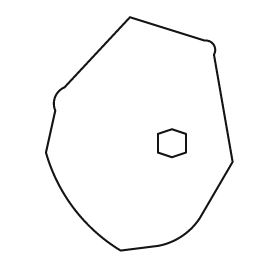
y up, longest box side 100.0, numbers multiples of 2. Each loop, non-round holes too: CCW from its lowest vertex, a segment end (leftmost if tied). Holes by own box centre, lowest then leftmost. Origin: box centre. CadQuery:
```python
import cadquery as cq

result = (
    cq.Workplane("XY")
    .moveTo(-8.0, -50.0)
    .lineTo(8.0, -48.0)
    .threePointArc((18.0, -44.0), (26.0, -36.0))
    .lineTo(40.0, -12.0)
    .lineTo(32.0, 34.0)
    .threePointArc((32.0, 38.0), (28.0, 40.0))
    .lineTo(-4.0, 50.0)
    .lineTo(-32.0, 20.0)
    .threePointArc((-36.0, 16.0), (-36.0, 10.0))
    .lineTo(-40.0, -8.0)
    .threePointArc((-28.0, -32.0), (-8.0, -50.0))
    .close()
    .moveTo(14.0, -10.0)
    .lineTo(20.0, -8.0)
    .lineTo(20.0, 0.0)
    .lineTo(14.0, 2.0)
    .lineTo(8.0, 0.0)
    .lineTo(8.0, -8.0)
    .close()
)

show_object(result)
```